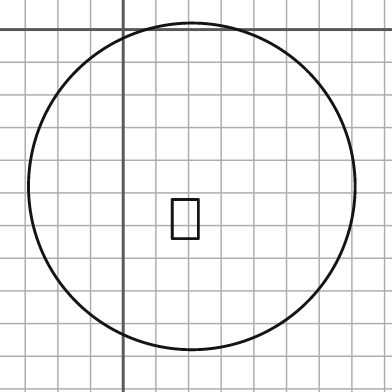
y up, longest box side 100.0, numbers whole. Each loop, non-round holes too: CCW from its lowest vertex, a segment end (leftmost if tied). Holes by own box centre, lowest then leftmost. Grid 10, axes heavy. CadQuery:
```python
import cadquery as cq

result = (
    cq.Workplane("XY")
    .moveTo(21.0, -48.0)
    .circle(50.0)
    .moveTo(15.0, -64.0)
    .lineTo(23.0, -64.0)
    .lineTo(23.0, -52.0)
    .lineTo(15.0, -52.0)
    .close()
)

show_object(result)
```